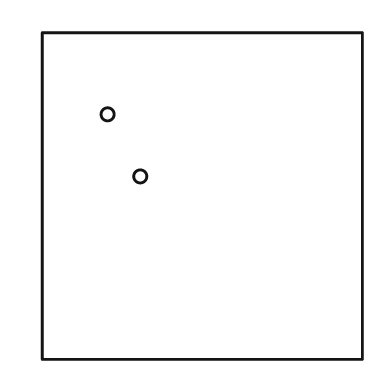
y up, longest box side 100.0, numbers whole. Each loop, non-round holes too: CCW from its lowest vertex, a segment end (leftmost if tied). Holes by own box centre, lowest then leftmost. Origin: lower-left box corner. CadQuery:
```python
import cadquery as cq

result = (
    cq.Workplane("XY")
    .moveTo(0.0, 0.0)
    .lineTo(98.0, 0.0)
    .lineTo(98.0, 100.0)
    .lineTo(0.0, 100.0)
    .close()
    .moveTo(30.0, 56.0)
    .circle(2.0)
    .moveTo(20.0, 75.0)
    .circle(2.0)
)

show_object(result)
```